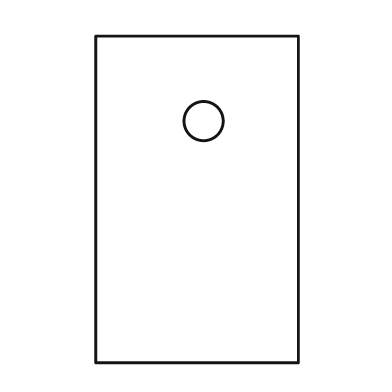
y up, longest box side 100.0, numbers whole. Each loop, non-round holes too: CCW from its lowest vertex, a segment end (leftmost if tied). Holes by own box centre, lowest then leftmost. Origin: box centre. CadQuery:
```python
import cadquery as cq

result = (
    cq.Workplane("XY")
    .moveTo(-31.0, -50.0)
    .lineTo(31.0, -50.0)
    .lineTo(31.0, 50.0)
    .lineTo(-31.0, 50.0)
    .close()
    .moveTo(2.0, 24.0)
    .circle(6.0)
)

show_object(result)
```